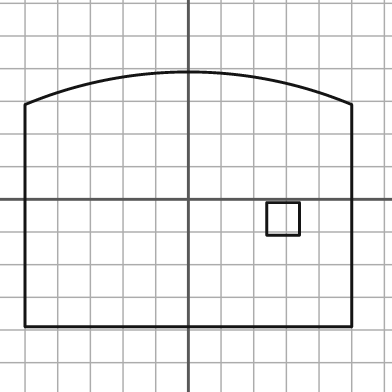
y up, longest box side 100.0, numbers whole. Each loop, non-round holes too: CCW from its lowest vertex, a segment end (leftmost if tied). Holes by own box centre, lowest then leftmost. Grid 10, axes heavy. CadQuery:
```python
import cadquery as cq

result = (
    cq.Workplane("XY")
    .moveTo(-50.0, -39.0)
    .lineTo(50.0, -39.0)
    .lineTo(50.0, 29.0)
    .threePointArc((0.0, 39.0), (-50.0, 29.0))
    .close()
    .moveTo(24.0, -11.0)
    .lineTo(34.0, -11.0)
    .lineTo(34.0, -1.0)
    .lineTo(24.0, -1.0)
    .close()
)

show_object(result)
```